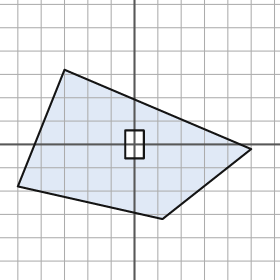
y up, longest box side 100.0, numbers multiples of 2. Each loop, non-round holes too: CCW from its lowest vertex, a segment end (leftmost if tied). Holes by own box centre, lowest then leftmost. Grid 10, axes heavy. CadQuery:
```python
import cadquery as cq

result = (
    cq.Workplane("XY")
    .moveTo(12.0, -32.0)
    .lineTo(50.0, -2.0)
    .lineTo(-30.0, 32.0)
    .lineTo(-50.0, -18.0)
    .close()
    .moveTo(-4.0, -6.0)
    .lineTo(4.0, -6.0)
    .lineTo(4.0, 6.0)
    .lineTo(-4.0, 6.0)
    .close()
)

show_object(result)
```